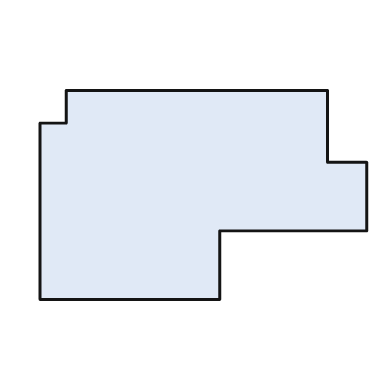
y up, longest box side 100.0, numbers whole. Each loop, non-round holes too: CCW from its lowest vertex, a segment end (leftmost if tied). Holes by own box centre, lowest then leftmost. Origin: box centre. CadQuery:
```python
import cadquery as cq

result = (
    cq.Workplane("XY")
    .moveTo(-50.0, -32.0)
    .lineTo(5.0, -32.0)
    .lineTo(5.0, -11.0)
    .lineTo(50.0, -11.0)
    .lineTo(50.0, 10.0)
    .lineTo(38.0, 10.0)
    .lineTo(38.0, 32.0)
    .lineTo(-42.0, 32.0)
    .lineTo(-42.0, 22.0)
    .lineTo(-50.0, 22.0)
    .close()
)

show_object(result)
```